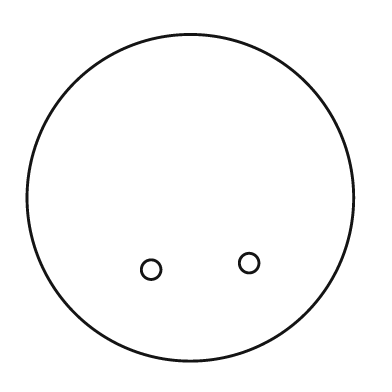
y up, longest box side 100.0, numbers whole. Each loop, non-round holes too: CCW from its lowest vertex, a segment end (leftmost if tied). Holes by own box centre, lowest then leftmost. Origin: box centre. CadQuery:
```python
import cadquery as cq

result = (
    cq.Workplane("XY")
    .moveTo(0.0, 0.0)
    .circle(50.0)
    .moveTo(-12.0, -22.0)
    .circle(3.0)
    .moveTo(18.0, -20.0)
    .circle(3.0)
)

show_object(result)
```